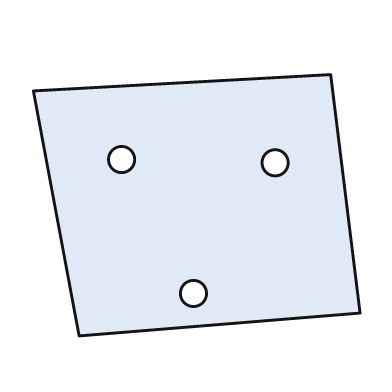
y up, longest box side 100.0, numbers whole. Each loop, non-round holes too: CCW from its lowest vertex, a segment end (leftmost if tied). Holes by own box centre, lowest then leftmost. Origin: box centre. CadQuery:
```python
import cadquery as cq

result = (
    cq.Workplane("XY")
    .moveTo(-36.0, -40.0)
    .lineTo(50.0, -33.0)
    .lineTo(41.0, 40.0)
    .lineTo(-50.0, 35.0)
    .close()
    .moveTo(-1.0, -27.0)
    .circle(4.0)
    .moveTo(24.0, 13.0)
    .circle(4.0)
    .moveTo(-23.0, 14.0)
    .circle(4.0)
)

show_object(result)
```